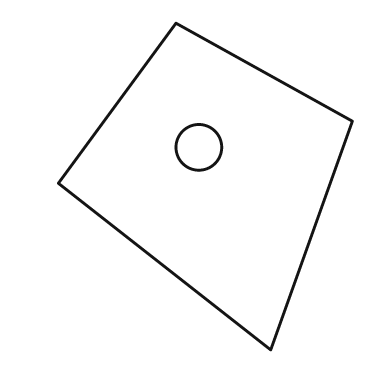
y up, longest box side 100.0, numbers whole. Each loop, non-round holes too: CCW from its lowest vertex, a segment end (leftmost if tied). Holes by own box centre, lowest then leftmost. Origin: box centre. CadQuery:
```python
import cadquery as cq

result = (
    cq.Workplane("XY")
    .moveTo(20.0, -50.0)
    .lineTo(45.0, 20.0)
    .lineTo(-9.0, 50.0)
    .lineTo(-45.0, 1.0)
    .close()
    .moveTo(-2.0, 12.0)
    .circle(7.0)
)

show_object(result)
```